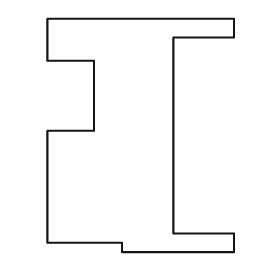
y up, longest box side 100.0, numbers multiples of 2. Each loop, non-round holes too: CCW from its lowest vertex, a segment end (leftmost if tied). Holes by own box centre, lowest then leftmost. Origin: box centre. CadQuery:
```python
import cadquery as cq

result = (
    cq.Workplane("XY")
    .moveTo(-8.0, -50.0)
    .lineTo(40.0, -50.0)
    .lineTo(40.0, -42.0)
    .lineTo(14.0, -42.0)
    .lineTo(14.0, 42.0)
    .lineTo(40.0, 42.0)
    .lineTo(40.0, 50.0)
    .lineTo(-40.0, 50.0)
    .lineTo(-40.0, 32.0)
    .lineTo(-20.0, 32.0)
    .lineTo(-20.0, 2.0)
    .lineTo(-40.0, 2.0)
    .lineTo(-40.0, -46.0)
    .lineTo(-8.0, -46.0)
    .close()
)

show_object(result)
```